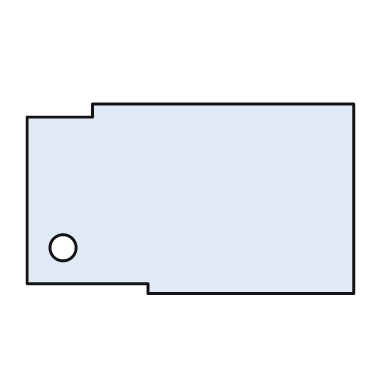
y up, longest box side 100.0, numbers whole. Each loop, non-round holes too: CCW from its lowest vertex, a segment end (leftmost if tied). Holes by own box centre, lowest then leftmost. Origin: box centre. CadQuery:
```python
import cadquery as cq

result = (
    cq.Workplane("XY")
    .moveTo(-13.0, -29.0)
    .lineTo(50.0, -29.0)
    .lineTo(50.0, 29.0)
    .lineTo(-30.0, 29.0)
    .lineTo(-30.0, 25.0)
    .lineTo(-50.0, 25.0)
    .lineTo(-50.0, -26.0)
    .lineTo(-13.0, -26.0)
    .close()
    .moveTo(-39.0, -15.0)
    .circle(4.0)
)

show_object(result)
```